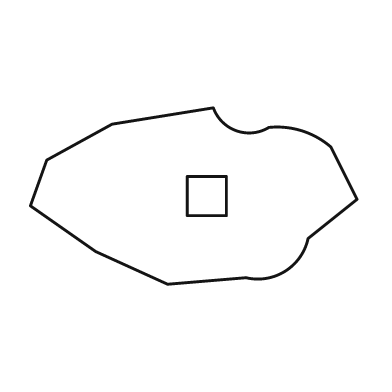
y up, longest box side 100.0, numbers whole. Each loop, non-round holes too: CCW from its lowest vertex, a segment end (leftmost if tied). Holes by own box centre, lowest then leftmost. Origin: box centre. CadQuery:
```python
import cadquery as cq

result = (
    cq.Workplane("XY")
    .moveTo(-8.0, -27.0)
    .lineTo(16.0, -25.0)
    .threePointArc((28.0, -23.0), (35.0, -13.0))
    .lineTo(50.0, -1.0)
    .lineTo(42.0, 15.0)
    .threePointArc((33.0, 20.0), (23.0, 21.0))
    .threePointArc((13.0, 20.0), (6.0, 27.0))
    .lineTo(-25.0, 22.0)
    .lineTo(-45.0, 11.0)
    .lineTo(-50.0, -3.0)
    .lineTo(-30.0, -17.0)
    .close()
    .moveTo(-2.0, -6.0)
    .lineTo(10.0, -6.0)
    .lineTo(10.0, 6.0)
    .lineTo(-2.0, 6.0)
    .close()
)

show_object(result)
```